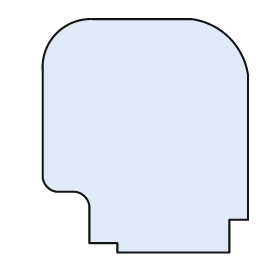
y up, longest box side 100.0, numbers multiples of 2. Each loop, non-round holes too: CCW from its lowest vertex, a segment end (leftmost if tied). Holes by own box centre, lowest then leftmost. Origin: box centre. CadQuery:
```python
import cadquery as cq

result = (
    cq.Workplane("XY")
    .moveTo(-12.0, -50.0)
    .lineTo(36.0, -50.0)
    .lineTo(36.0, -36.0)
    .lineTo(44.0, -36.0)
    .lineTo(44.0, 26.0)
    .threePointArc((36.0, 42.0), (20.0, 50.0))
    .lineTo(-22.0, 50.0)
    .threePointArc((-38.0, 44.0), (-44.0, 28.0))
    .lineTo(-44.0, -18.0)
    .threePointArc((-42.0, -22.0), (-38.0, -24.0))
    .lineTo(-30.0, -24.0)
    .threePointArc((-26.0, -26.0), (-24.0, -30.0))
    .lineTo(-24.0, -46.0)
    .lineTo(-12.0, -46.0)
    .close()
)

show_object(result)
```